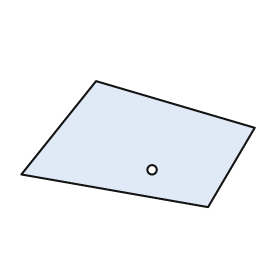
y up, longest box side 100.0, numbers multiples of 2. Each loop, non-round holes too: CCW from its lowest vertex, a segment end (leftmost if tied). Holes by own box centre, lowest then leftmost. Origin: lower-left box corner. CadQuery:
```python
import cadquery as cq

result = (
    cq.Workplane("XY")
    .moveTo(80.0, 0.0)
    .lineTo(100.0, 34.0)
    .lineTo(32.0, 54.0)
    .lineTo(0.0, 14.0)
    .close()
    .moveTo(56.0, 16.0)
    .circle(2.0)
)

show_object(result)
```